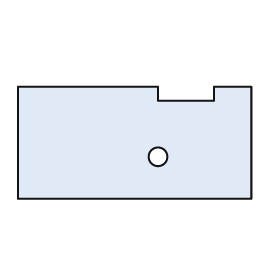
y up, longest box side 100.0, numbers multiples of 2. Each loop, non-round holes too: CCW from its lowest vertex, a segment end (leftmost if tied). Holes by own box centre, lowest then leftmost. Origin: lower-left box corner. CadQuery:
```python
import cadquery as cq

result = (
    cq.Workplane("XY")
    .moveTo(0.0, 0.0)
    .lineTo(100.0, 0.0)
    .lineTo(100.0, 48.0)
    .lineTo(84.0, 48.0)
    .lineTo(84.0, 42.0)
    .lineTo(60.0, 42.0)
    .lineTo(60.0, 48.0)
    .lineTo(0.0, 48.0)
    .close()
    .moveTo(60.0, 18.0)
    .circle(4.0)
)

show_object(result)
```